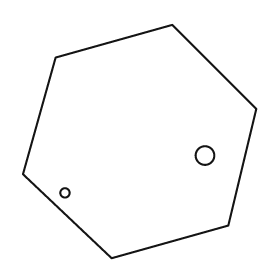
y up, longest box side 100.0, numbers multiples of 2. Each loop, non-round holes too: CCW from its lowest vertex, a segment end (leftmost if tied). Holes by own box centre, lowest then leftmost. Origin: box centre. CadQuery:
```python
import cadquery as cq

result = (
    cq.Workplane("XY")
    .moveTo(-12.0, -50.0)
    .lineTo(38.0, -36.0)
    .lineTo(50.0, 14.0)
    .lineTo(14.0, 50.0)
    .lineTo(-36.0, 36.0)
    .lineTo(-50.0, -14.0)
    .close()
    .moveTo(-32.0, -22.0)
    .circle(2.0)
    .moveTo(28.0, -6.0)
    .circle(4.0)
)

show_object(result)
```